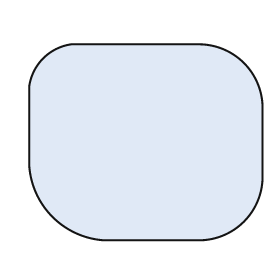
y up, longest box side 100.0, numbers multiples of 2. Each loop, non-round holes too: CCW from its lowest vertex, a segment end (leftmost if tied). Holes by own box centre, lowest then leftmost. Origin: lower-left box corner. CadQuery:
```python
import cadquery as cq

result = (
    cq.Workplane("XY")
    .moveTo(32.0, 0.0)
    .lineTo(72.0, 0.0)
    .threePointArc((92.0, 8.0), (100.0, 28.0))
    .lineTo(100.0, 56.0)
    .threePointArc((92.0, 76.0), (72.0, 84.0))
    .lineTo(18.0, 84.0)
    .threePointArc((6.0, 78.0), (0.0, 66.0))
    .lineTo(0.0, 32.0)
    .threePointArc((10.0, 10.0), (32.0, 0.0))
    .close()
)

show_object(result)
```